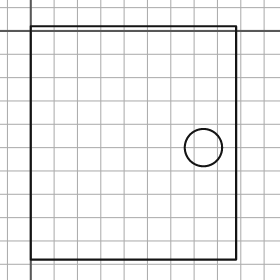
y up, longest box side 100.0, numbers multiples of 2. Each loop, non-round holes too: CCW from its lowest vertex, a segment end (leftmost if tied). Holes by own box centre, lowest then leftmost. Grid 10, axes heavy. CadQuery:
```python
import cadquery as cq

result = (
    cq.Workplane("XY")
    .moveTo(0.0, -98.0)
    .lineTo(88.0, -98.0)
    .lineTo(88.0, 2.0)
    .lineTo(0.0, 2.0)
    .close()
    .moveTo(74.0, -50.0)
    .circle(8.0)
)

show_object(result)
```